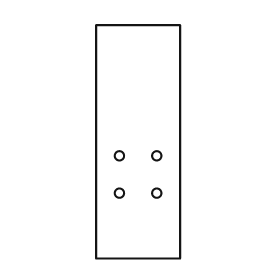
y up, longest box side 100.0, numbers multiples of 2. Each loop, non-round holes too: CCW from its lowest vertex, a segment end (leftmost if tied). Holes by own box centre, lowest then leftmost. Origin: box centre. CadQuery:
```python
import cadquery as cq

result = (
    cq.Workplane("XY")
    .moveTo(-18.0, -50.0)
    .lineTo(18.0, -50.0)
    .lineTo(18.0, 50.0)
    .lineTo(-18.0, 50.0)
    .close()
    .moveTo(-8.0, -22.0)
    .circle(2.0)
    .moveTo(8.0, -22.0)
    .circle(2.0)
    .moveTo(-8.0, -6.0)
    .circle(2.0)
    .moveTo(8.0, -6.0)
    .circle(2.0)
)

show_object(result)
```